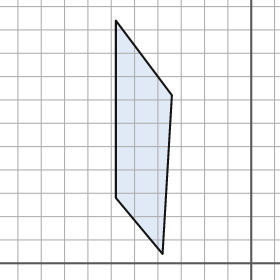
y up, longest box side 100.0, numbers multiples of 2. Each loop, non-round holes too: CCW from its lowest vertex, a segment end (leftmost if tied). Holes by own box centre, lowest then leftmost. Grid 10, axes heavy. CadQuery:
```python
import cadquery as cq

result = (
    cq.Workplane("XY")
    .moveTo(-38.0, 4.0)
    .lineTo(-34.0, 72.0)
    .lineTo(-58.0, 104.0)
    .lineTo(-58.0, 28.0)
    .close()
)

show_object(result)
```